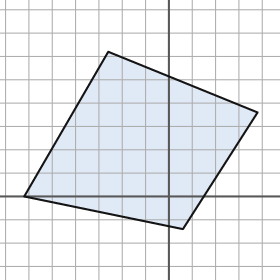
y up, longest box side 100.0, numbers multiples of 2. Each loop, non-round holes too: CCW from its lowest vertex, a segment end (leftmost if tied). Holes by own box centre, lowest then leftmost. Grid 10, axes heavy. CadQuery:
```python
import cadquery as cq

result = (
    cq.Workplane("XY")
    .moveTo(6.0, -14.0)
    .lineTo(38.0, 36.0)
    .lineTo(-26.0, 62.0)
    .lineTo(-62.0, 0.0)
    .close()
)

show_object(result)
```